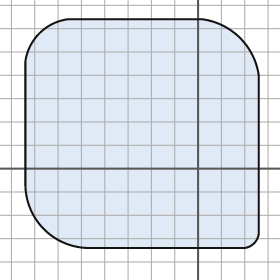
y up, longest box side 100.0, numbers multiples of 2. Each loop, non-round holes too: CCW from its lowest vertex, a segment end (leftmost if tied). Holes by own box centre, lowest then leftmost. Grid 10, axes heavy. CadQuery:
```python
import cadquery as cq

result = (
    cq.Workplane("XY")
    .moveTo(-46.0, -34.0)
    .lineTo(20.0, -34.0)
    .threePointArc((24.0, -32.0), (26.0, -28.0))
    .lineTo(26.0, 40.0)
    .threePointArc((18.0, 56.0), (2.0, 64.0))
    .lineTo(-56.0, 64.0)
    .threePointArc((-68.0, 58.0), (-74.0, 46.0))
    .lineTo(-74.0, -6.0)
    .threePointArc((-66.0, -26.0), (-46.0, -34.0))
    .close()
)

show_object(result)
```